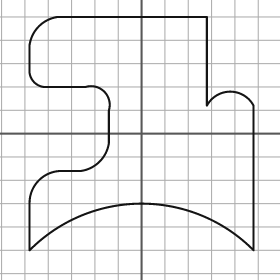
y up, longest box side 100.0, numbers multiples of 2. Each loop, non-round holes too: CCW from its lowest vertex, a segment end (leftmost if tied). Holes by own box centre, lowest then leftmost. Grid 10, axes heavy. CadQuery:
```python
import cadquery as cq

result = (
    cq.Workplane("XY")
    .moveTo(-48.0, -50.0)
    .threePointArc((0.0, -30.0), (48.0, -50.0))
    .lineTo(48.0, 12.0)
    .threePointArc((38.0, 18.0), (28.0, 12.0))
    .lineTo(28.0, 50.0)
    .lineTo(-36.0, 50.0)
    .threePointArc((-44.0, 46.0), (-48.0, 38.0))
    .lineTo(-48.0, 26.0)
    .threePointArc((-46.0, 22.0), (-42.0, 20.0))
    .lineTo(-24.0, 20.0)
    .threePointArc((-16.0, 18.0), (-14.0, 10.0))
    .lineTo(-14.0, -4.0)
    .threePointArc((-18.0, -12.0), (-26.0, -16.0))
    .lineTo(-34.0, -16.0)
    .threePointArc((-44.0, -20.0), (-48.0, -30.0))
    .close()
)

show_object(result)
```